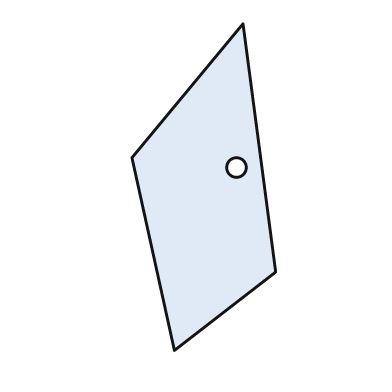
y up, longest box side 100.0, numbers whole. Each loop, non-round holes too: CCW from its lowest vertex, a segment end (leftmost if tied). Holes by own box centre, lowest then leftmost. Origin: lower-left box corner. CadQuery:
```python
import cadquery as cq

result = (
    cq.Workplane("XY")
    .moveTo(13.0, 0.0)
    .lineTo(44.0, 24.0)
    .lineTo(34.0, 100.0)
    .lineTo(0.0, 59.0)
    .close()
    .moveTo(32.0, 56.0)
    .circle(3.0)
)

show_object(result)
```